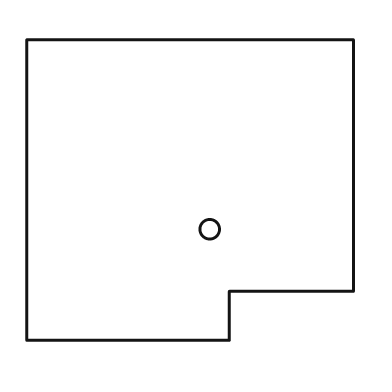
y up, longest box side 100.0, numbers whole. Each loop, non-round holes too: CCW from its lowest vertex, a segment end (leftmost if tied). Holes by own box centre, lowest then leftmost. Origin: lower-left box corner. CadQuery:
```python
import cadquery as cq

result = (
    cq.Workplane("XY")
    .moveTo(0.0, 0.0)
    .lineTo(62.0, 0.0)
    .lineTo(62.0, 15.0)
    .lineTo(100.0, 15.0)
    .lineTo(100.0, 92.0)
    .lineTo(0.0, 92.0)
    .close()
    .moveTo(56.0, 34.0)
    .circle(3.0)
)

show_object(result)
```